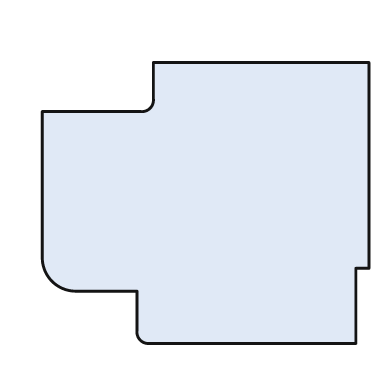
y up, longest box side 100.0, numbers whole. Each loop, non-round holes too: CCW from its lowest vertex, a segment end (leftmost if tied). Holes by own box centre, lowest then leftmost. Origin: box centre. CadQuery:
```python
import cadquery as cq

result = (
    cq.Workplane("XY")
    .moveTo(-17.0, -43.0)
    .lineTo(46.0, -43.0)
    .lineTo(46.0, -20.0)
    .lineTo(50.0, -20.0)
    .lineTo(50.0, 43.0)
    .lineTo(-16.0, 43.0)
    .lineTo(-16.0, 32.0)
    .threePointArc((-17.0, 29.0), (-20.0, 28.0))
    .lineTo(-50.0, 28.0)
    .lineTo(-50.0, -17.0)
    .threePointArc((-47.0, -24.0), (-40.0, -27.0))
    .lineTo(-21.0, -27.0)
    .lineTo(-21.0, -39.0)
    .threePointArc((-20.0, -42.0), (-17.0, -43.0))
    .close()
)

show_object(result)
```